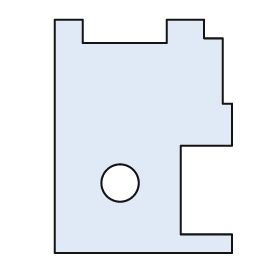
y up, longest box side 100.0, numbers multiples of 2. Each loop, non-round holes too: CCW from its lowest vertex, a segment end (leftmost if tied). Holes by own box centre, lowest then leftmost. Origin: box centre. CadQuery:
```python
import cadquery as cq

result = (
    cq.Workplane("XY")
    .moveTo(-38.0, -50.0)
    .lineTo(38.0, -50.0)
    .lineTo(38.0, -42.0)
    .lineTo(16.0, -42.0)
    .lineTo(16.0, -4.0)
    .lineTo(38.0, -4.0)
    .lineTo(38.0, 14.0)
    .lineTo(34.0, 14.0)
    .lineTo(34.0, 42.0)
    .lineTo(26.0, 42.0)
    .lineTo(26.0, 50.0)
    .lineTo(10.0, 50.0)
    .lineTo(10.0, 40.0)
    .lineTo(-26.0, 40.0)
    .lineTo(-26.0, 50.0)
    .lineTo(-38.0, 50.0)
    .close()
    .moveTo(-10.0, -20.0)
    .circle(8.0)
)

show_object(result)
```